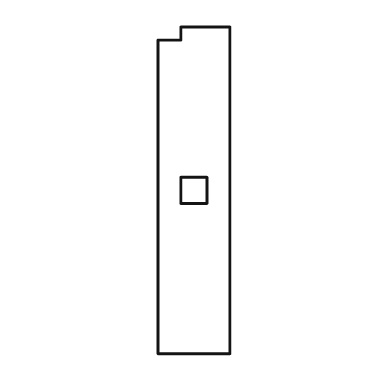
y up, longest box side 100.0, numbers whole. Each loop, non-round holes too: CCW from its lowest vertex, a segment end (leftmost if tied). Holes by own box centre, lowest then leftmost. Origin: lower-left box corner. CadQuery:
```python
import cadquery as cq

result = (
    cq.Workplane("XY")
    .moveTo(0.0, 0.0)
    .lineTo(22.0, 0.0)
    .lineTo(22.0, 100.0)
    .lineTo(7.0, 100.0)
    .lineTo(7.0, 96.0)
    .lineTo(0.0, 96.0)
    .close()
    .moveTo(7.0, 46.0)
    .lineTo(15.0, 46.0)
    .lineTo(15.0, 54.0)
    .lineTo(7.0, 54.0)
    .close()
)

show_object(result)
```